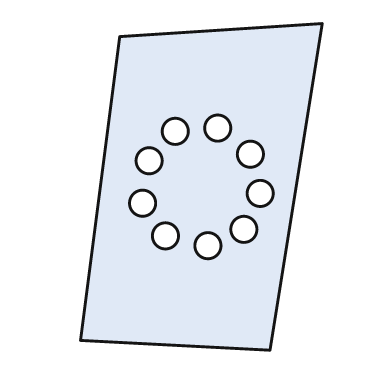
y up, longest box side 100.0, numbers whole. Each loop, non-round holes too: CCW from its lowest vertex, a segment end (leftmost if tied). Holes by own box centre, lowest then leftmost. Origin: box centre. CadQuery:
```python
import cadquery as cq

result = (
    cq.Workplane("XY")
    .moveTo(21.0, -50.0)
    .lineTo(37.0, 50.0)
    .lineTo(-25.0, 46.0)
    .lineTo(-37.0, -47.0)
    .close()
    .moveTo(2.0, -18.0)
    .circle(4.0)
    .moveTo(-11.0, -15.0)
    .circle(4.0)
    .moveTo(13.0, -13.0)
    .circle(4.0)
    .moveTo(-18.0, -5.0)
    .circle(4.0)
    .moveTo(18.0, -2.0)
    .circle(4.0)
    .moveTo(-16.0, 8.0)
    .circle(4.0)
    .moveTo(15.0, 10.0)
    .circle(4.0)
    .moveTo(-8.0, 17.0)
    .circle(4.0)
    .moveTo(5.0, 18.0)
    .circle(4.0)
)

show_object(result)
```